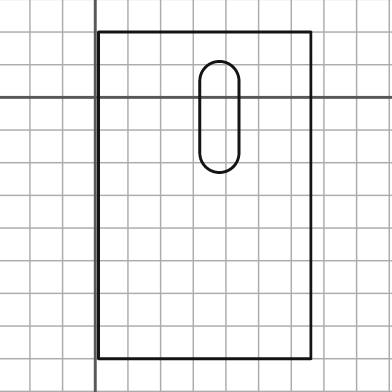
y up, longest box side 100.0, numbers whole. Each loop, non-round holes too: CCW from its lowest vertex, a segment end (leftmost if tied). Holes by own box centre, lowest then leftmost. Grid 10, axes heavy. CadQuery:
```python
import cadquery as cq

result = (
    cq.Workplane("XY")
    .moveTo(1.0, -80.0)
    .lineTo(66.0, -80.0)
    .lineTo(66.0, 20.0)
    .lineTo(1.0, 20.0)
    .close()
    .moveTo(32.0, -17.0)
    .threePointArc((38.0, -23.0), (44.0, -17.0))
    .lineTo(44.0, 5.0)
    .threePointArc((38.0, 11.0), (32.0, 5.0))
    .close()
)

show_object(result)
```